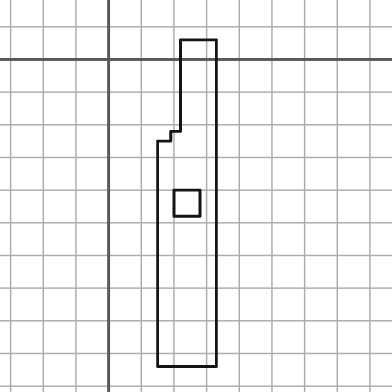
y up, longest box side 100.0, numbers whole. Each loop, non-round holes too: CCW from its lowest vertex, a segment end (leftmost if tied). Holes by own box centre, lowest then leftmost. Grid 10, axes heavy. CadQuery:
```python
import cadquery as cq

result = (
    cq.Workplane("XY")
    .moveTo(15.0, -94.0)
    .lineTo(33.0, -94.0)
    .lineTo(33.0, 6.0)
    .lineTo(22.0, 6.0)
    .lineTo(22.0, -22.0)
    .lineTo(19.0, -22.0)
    .lineTo(19.0, -25.0)
    .lineTo(15.0, -25.0)
    .close()
    .moveTo(20.0, -48.0)
    .lineTo(28.0, -48.0)
    .lineTo(28.0, -40.0)
    .lineTo(20.0, -40.0)
    .close()
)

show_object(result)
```